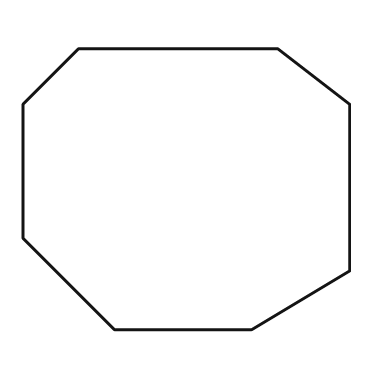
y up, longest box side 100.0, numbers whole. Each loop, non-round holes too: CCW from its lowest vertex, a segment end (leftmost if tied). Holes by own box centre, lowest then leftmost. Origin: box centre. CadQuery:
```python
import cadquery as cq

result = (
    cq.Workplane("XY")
    .moveTo(-22.0, -43.0)
    .lineTo(20.0, -43.0)
    .lineTo(50.0, -25.0)
    .lineTo(50.0, 26.0)
    .lineTo(28.0, 43.0)
    .lineTo(-33.0, 43.0)
    .lineTo(-50.0, 26.0)
    .lineTo(-50.0, -15.0)
    .close()
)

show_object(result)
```